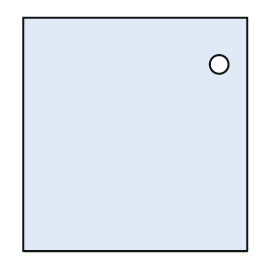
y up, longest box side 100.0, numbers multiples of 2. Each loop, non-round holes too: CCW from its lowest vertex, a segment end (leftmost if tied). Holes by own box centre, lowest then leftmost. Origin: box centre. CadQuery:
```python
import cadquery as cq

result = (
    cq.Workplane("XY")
    .moveTo(-48.0, -50.0)
    .lineTo(48.0, -50.0)
    .lineTo(48.0, 50.0)
    .lineTo(-48.0, 50.0)
    .close()
    .moveTo(36.0, 30.0)
    .circle(4.0)
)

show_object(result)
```